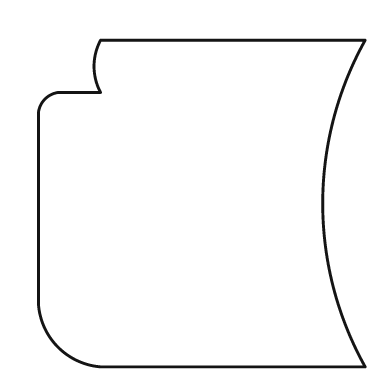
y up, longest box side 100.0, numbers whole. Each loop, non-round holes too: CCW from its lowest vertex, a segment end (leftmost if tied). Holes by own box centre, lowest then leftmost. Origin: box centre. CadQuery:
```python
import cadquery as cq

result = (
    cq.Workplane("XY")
    .moveTo(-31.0, -50.0)
    .lineTo(50.0, -50.0)
    .threePointArc((37.0, 0.0), (50.0, 50.0))
    .lineTo(-31.0, 50.0)
    .threePointArc((-33.0, 42.0), (-31.0, 34.0))
    .lineTo(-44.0, 34.0)
    .threePointArc((-48.0, 32.0), (-50.0, 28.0))
    .lineTo(-50.0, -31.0)
    .threePointArc((-44.0, -44.0), (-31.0, -50.0))
    .close()
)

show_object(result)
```